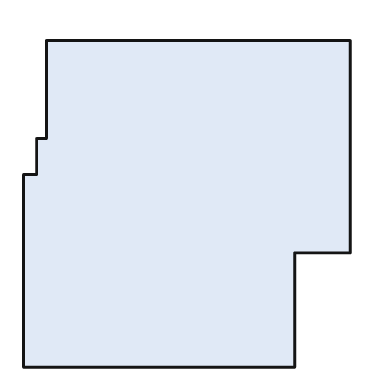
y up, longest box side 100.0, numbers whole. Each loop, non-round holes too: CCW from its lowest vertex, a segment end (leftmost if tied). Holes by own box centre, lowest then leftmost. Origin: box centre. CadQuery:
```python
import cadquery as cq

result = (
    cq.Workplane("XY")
    .moveTo(-50.0, -50.0)
    .lineTo(33.0, -50.0)
    .lineTo(33.0, -15.0)
    .lineTo(50.0, -15.0)
    .lineTo(50.0, 50.0)
    .lineTo(-43.0, 50.0)
    .lineTo(-43.0, 20.0)
    .lineTo(-46.0, 20.0)
    .lineTo(-46.0, 9.0)
    .lineTo(-50.0, 9.0)
    .close()
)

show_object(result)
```